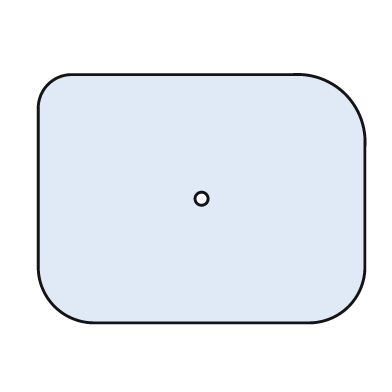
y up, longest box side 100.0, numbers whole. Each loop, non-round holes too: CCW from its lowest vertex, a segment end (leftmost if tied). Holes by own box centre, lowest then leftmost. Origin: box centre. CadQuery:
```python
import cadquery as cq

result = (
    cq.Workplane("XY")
    .moveTo(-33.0, -38.0)
    .lineTo(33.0, -38.0)
    .threePointArc((45.0, -33.0), (50.0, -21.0))
    .lineTo(50.0, 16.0)
    .threePointArc((44.0, 32.0), (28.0, 38.0))
    .lineTo(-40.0, 38.0)
    .threePointArc((-47.0, 35.0), (-50.0, 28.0))
    .lineTo(-50.0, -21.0)
    .threePointArc((-45.0, -33.0), (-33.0, -38.0))
    .close()
    .moveTo(0.0, 0.0)
    .circle(2.0)
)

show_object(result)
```